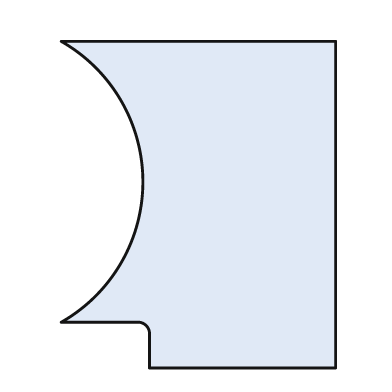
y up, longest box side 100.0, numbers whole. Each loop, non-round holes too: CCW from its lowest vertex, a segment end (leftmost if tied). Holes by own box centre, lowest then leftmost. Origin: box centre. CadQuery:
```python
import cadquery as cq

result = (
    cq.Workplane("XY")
    .moveTo(-15.0, -50.0)
    .lineTo(42.0, -50.0)
    .lineTo(42.0, 50.0)
    .lineTo(-42.0, 50.0)
    .threePointArc((-17.0, 7.0), (-42.0, -36.0))
    .lineTo(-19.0, -36.0)
    .threePointArc((-16.0, -37.0), (-15.0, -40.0))
    .close()
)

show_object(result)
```